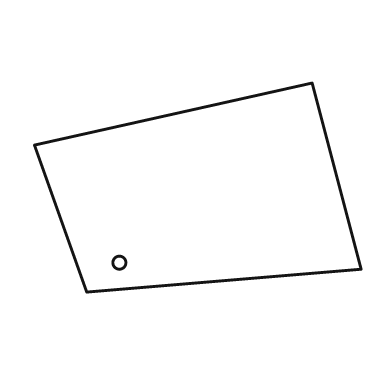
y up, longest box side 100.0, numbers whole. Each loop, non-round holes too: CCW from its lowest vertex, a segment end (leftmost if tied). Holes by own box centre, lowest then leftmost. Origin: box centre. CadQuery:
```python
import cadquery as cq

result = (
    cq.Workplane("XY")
    .moveTo(-34.0, -32.0)
    .lineTo(50.0, -25.0)
    .lineTo(35.0, 32.0)
    .lineTo(-50.0, 13.0)
    .close()
    .moveTo(-24.0, -23.0)
    .circle(2.0)
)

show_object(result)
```